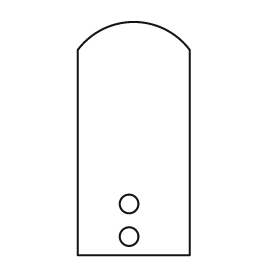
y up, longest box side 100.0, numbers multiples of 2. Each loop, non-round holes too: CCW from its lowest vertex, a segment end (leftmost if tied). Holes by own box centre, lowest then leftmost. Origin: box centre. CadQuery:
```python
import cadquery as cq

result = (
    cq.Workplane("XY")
    .moveTo(-24.0, -50.0)
    .lineTo(24.0, -50.0)
    .lineTo(24.0, 38.0)
    .threePointArc((0.0, 50.0), (-24.0, 38.0))
    .close()
    .moveTo(-2.0, -42.0)
    .circle(4.0)
    .moveTo(-2.0, -28.0)
    .circle(4.0)
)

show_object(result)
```